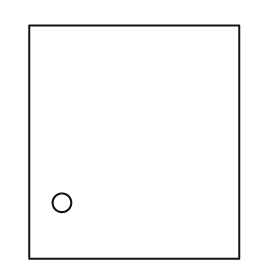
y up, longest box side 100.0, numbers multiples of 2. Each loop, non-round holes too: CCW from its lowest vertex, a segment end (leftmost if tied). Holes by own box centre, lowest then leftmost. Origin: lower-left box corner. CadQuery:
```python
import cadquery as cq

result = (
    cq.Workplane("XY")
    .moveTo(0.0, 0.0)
    .lineTo(90.0, 0.0)
    .lineTo(90.0, 100.0)
    .lineTo(0.0, 100.0)
    .close()
    .moveTo(14.0, 24.0)
    .circle(4.0)
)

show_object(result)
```